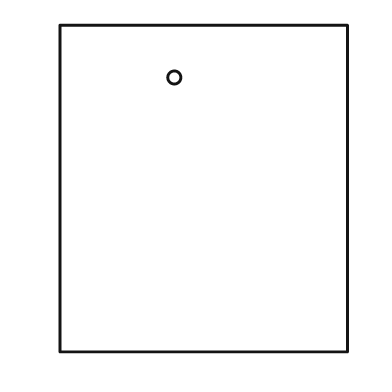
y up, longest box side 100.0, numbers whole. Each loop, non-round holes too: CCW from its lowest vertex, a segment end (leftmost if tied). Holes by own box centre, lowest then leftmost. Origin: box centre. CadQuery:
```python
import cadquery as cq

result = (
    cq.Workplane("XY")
    .moveTo(-44.0, -50.0)
    .lineTo(44.0, -50.0)
    .lineTo(44.0, 50.0)
    .lineTo(-44.0, 50.0)
    .close()
    .moveTo(-9.0, 34.0)
    .circle(2.0)
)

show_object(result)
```